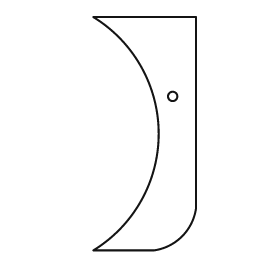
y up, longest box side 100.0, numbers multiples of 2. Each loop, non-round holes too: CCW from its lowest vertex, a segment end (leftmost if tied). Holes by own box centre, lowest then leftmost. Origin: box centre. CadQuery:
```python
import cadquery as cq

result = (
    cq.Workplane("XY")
    .moveTo(-22.0, -50.0)
    .lineTo(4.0, -50.0)
    .threePointArc((16.0, -44.0), (22.0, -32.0))
    .lineTo(22.0, 50.0)
    .lineTo(-22.0, 50.0)
    .threePointArc((6.0, 0.0), (-22.0, -50.0))
    .close()
    .moveTo(12.0, 16.0)
    .circle(2.0)
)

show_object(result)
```